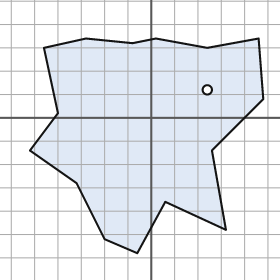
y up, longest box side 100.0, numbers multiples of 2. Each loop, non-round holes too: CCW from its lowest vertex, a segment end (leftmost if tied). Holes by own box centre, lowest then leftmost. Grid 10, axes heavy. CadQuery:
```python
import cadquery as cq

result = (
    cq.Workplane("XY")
    .moveTo(-6.0, -58.0)
    .lineTo(6.0, -36.0)
    .lineTo(32.0, -48.0)
    .lineTo(26.0, -14.0)
    .lineTo(48.0, 8.0)
    .lineTo(46.0, 34.0)
    .lineTo(24.0, 30.0)
    .lineTo(2.0, 34.0)
    .lineTo(-8.0, 32.0)
    .lineTo(-28.0, 34.0)
    .lineTo(-46.0, 30.0)
    .lineTo(-40.0, 2.0)
    .lineTo(-52.0, -14.0)
    .lineTo(-32.0, -28.0)
    .lineTo(-20.0, -52.0)
    .close()
    .moveTo(24.0, 12.0)
    .circle(2.0)
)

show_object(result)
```